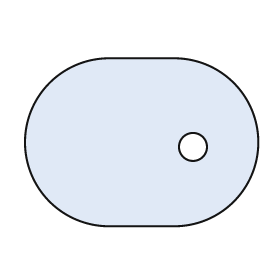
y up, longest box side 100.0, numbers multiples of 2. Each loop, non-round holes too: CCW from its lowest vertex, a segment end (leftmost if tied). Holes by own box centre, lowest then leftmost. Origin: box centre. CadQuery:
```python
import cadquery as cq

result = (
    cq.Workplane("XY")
    .moveTo(-14.0, -36.0)
    .lineTo(14.0, -36.0)
    .threePointArc((50.0, 0.0), (14.0, 36.0))
    .lineTo(-14.0, 36.0)
    .threePointArc((-50.0, 0.0), (-14.0, -36.0))
    .close()
    .moveTo(22.0, -2.0)
    .circle(6.0)
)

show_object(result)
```